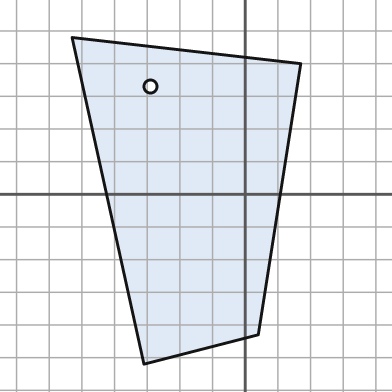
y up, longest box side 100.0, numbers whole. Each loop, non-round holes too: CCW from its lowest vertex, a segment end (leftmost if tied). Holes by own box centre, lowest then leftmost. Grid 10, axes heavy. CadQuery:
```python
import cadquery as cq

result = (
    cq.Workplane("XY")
    .moveTo(-31.0, -52.0)
    .lineTo(4.0, -43.0)
    .lineTo(17.0, 40.0)
    .lineTo(-53.0, 48.0)
    .close()
    .moveTo(-29.0, 33.0)
    .circle(2.0)
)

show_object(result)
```